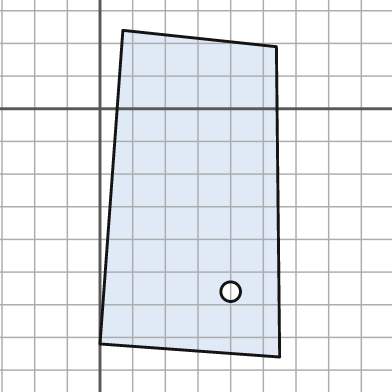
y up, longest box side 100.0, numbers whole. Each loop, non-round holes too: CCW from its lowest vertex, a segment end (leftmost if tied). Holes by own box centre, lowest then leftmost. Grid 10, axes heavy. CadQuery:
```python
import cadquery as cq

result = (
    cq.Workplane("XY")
    .moveTo(55.0, -76.0)
    .lineTo(54.0, 19.0)
    .lineTo(7.0, 24.0)
    .lineTo(0.0, -72.0)
    .close()
    .moveTo(40.0, -56.0)
    .circle(3.0)
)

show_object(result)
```